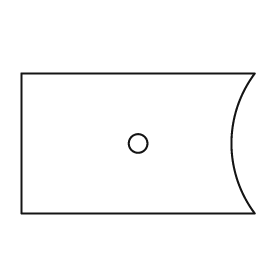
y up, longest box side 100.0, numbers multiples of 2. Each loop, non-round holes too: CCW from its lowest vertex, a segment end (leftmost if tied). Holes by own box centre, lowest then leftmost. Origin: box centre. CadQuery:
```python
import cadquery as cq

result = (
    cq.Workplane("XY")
    .moveTo(-50.0, -30.0)
    .lineTo(50.0, -30.0)
    .threePointArc((40.0, 0.0), (50.0, 30.0))
    .lineTo(-50.0, 30.0)
    .close()
    .moveTo(0.0, 0.0)
    .circle(4.0)
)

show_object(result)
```